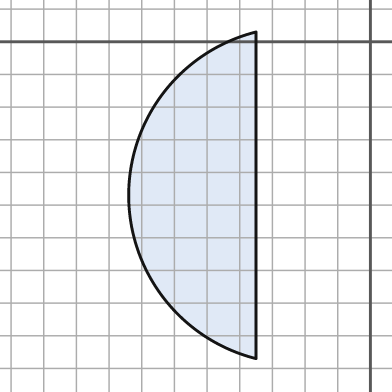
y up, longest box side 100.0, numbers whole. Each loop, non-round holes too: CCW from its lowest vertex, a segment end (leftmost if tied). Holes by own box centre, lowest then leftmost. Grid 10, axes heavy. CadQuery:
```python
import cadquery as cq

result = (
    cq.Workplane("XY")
    .moveTo(-35.0, -97.0)
    .lineTo(-35.0, 3.0)
    .threePointArc((-74.0, -47.0), (-35.0, -97.0))
    .close()
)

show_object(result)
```